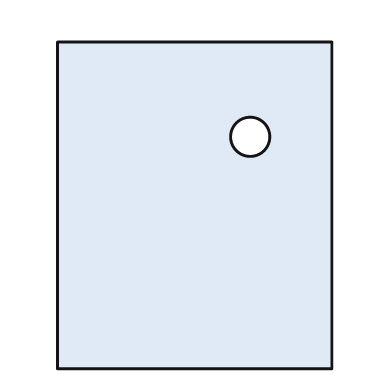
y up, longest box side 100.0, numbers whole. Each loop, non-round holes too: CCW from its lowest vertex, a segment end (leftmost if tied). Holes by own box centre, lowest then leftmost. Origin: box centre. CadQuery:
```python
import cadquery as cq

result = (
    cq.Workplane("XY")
    .moveTo(-42.0, -50.0)
    .lineTo(42.0, -50.0)
    .lineTo(42.0, 50.0)
    .lineTo(-42.0, 50.0)
    .close()
    .moveTo(17.0, 21.0)
    .circle(6.0)
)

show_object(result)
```